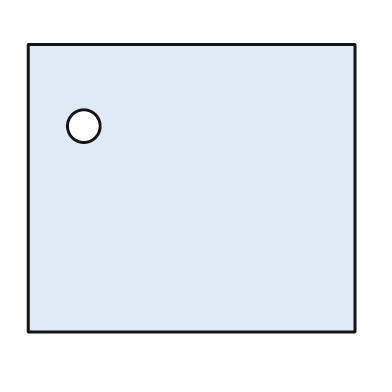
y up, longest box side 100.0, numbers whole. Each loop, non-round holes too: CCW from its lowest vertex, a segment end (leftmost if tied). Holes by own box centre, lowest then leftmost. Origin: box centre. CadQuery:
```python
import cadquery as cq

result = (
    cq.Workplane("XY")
    .moveTo(-50.0, -44.0)
    .lineTo(50.0, -44.0)
    .lineTo(50.0, 44.0)
    .lineTo(-50.0, 44.0)
    .close()
    .moveTo(-33.0, 19.0)
    .circle(5.0)
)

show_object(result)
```